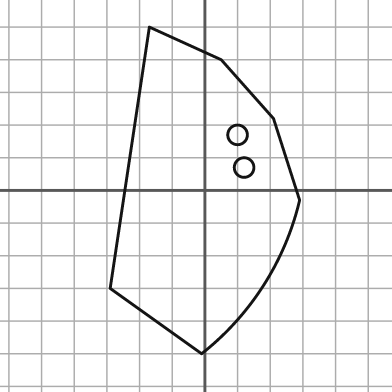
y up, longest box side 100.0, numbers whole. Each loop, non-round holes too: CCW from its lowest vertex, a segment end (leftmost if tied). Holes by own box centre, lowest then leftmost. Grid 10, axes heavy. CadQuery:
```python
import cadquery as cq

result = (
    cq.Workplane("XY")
    .moveTo(-1.0, -50.0)
    .threePointArc((18.0, -29.0), (29.0, -3.0))
    .lineTo(21.0, 22.0)
    .lineTo(5.0, 40.0)
    .lineTo(-17.0, 50.0)
    .lineTo(-29.0, -30.0)
    .close()
    .moveTo(12.0, 7.0)
    .circle(3.0)
    .moveTo(10.0, 17.0)
    .circle(3.0)
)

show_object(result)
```